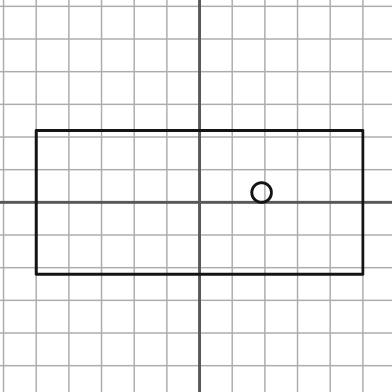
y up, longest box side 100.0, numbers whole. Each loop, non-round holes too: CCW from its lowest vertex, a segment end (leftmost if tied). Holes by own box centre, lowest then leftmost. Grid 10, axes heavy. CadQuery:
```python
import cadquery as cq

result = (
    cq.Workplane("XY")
    .moveTo(-50.0, -22.0)
    .lineTo(50.0, -22.0)
    .lineTo(50.0, 22.0)
    .lineTo(-50.0, 22.0)
    .close()
    .moveTo(19.0, 3.0)
    .circle(3.0)
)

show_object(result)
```